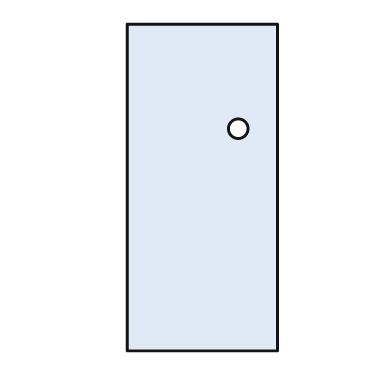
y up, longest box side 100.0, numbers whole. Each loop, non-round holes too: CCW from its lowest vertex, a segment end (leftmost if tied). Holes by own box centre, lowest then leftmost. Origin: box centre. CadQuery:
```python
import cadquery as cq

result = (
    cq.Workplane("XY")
    .moveTo(-23.0, -50.0)
    .lineTo(23.0, -50.0)
    .lineTo(23.0, 50.0)
    .lineTo(-23.0, 50.0)
    .close()
    .moveTo(11.0, 18.0)
    .circle(3.0)
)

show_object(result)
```